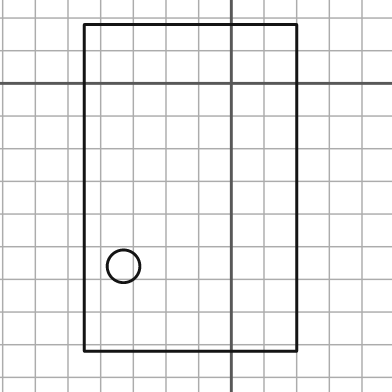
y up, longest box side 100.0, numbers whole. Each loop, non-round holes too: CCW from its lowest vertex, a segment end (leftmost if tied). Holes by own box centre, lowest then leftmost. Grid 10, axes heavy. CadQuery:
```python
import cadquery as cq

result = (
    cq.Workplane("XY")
    .moveTo(-45.0, -82.0)
    .lineTo(20.0, -82.0)
    .lineTo(20.0, 18.0)
    .lineTo(-45.0, 18.0)
    .close()
    .moveTo(-33.0, -56.0)
    .circle(5.0)
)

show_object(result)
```